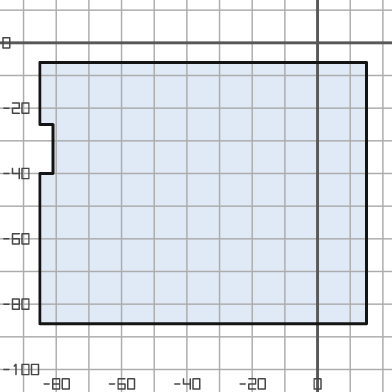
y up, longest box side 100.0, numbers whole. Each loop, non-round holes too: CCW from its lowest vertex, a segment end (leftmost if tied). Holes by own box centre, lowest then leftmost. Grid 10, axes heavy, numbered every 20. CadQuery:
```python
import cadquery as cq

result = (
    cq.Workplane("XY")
    .moveTo(-85.0, -86.0)
    .lineTo(15.0, -86.0)
    .lineTo(15.0, -6.0)
    .lineTo(-85.0, -6.0)
    .lineTo(-85.0, -25.0)
    .lineTo(-81.0, -25.0)
    .lineTo(-81.0, -40.0)
    .lineTo(-85.0, -40.0)
    .close()
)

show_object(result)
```